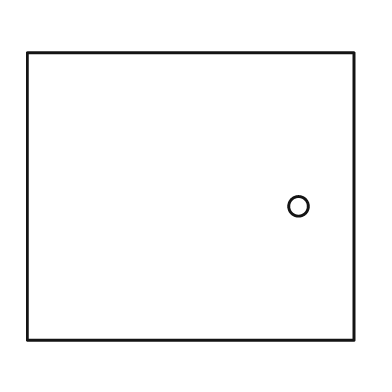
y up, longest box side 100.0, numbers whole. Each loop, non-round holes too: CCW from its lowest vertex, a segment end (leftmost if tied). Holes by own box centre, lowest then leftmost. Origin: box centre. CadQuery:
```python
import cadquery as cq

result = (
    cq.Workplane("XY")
    .moveTo(-50.0, -44.0)
    .lineTo(50.0, -44.0)
    .lineTo(50.0, 44.0)
    .lineTo(-50.0, 44.0)
    .close()
    .moveTo(33.0, -3.0)
    .circle(3.0)
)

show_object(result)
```